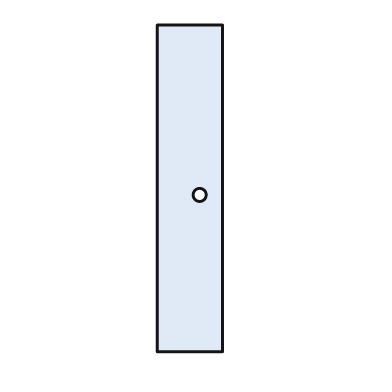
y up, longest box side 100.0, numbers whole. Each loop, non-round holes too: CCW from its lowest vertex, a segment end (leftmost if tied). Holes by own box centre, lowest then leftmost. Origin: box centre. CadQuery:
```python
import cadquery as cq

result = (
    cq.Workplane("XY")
    .moveTo(-10.0, -50.0)
    .lineTo(10.0, -50.0)
    .lineTo(10.0, 50.0)
    .lineTo(-10.0, 50.0)
    .close()
    .moveTo(3.0, -2.0)
    .circle(2.0)
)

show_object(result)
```